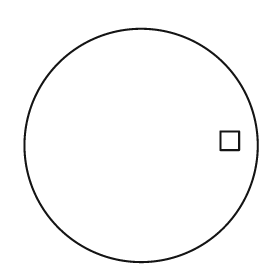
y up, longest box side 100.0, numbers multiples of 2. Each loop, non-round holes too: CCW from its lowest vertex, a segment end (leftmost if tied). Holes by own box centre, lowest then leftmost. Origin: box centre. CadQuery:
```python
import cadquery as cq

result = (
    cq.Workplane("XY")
    .moveTo(0.0, 0.0)
    .circle(50.0)
    .moveTo(34.0, -2.0)
    .lineTo(42.0, -2.0)
    .lineTo(42.0, 6.0)
    .lineTo(34.0, 6.0)
    .close()
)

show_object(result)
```